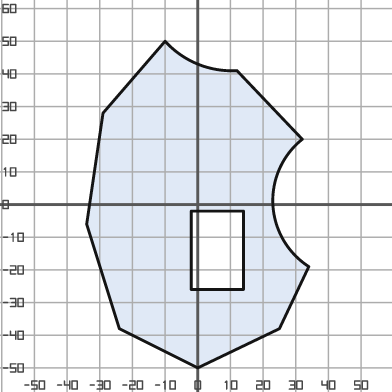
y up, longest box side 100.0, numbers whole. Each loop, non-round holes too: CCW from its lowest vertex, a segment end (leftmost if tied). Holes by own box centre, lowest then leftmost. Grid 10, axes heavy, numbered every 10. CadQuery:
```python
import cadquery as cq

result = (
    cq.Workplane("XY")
    .moveTo(0.0, -50.0)
    .lineTo(25.0, -38.0)
    .lineTo(34.0, -19.0)
    .threePointArc((23.0, 0.0), (32.0, 20.0))
    .lineTo(12.0, 41.0)
    .threePointArc((0.0, 43.0), (-10.0, 50.0))
    .lineTo(-29.0, 28.0)
    .lineTo(-34.0, -6.0)
    .lineTo(-24.0, -38.0)
    .close()
    .moveTo(-2.0, -26.0)
    .lineTo(14.0, -26.0)
    .lineTo(14.0, -2.0)
    .lineTo(-2.0, -2.0)
    .close()
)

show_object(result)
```